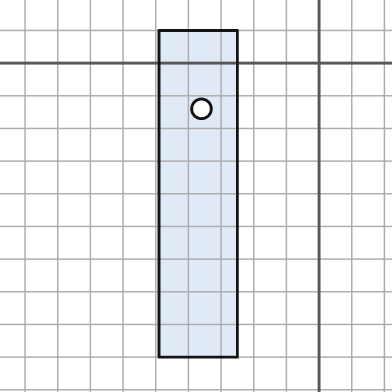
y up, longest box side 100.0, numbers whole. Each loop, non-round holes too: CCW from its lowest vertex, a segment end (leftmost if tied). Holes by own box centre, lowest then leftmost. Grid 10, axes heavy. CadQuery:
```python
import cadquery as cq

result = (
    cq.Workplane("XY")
    .moveTo(-49.0, -90.0)
    .lineTo(-25.0, -90.0)
    .lineTo(-25.0, 10.0)
    .lineTo(-49.0, 10.0)
    .close()
    .moveTo(-36.0, -14.0)
    .circle(3.0)
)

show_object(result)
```